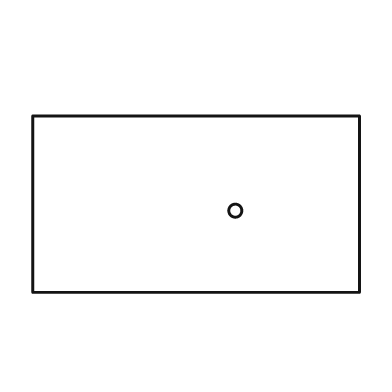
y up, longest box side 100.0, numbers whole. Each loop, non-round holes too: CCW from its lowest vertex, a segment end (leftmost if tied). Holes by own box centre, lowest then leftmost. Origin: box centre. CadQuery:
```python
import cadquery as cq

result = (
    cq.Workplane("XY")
    .moveTo(-50.0, -27.0)
    .lineTo(50.0, -27.0)
    .lineTo(50.0, 27.0)
    .lineTo(-50.0, 27.0)
    .close()
    .moveTo(12.0, -2.0)
    .circle(2.0)
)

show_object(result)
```